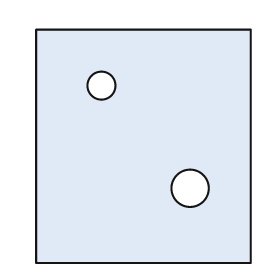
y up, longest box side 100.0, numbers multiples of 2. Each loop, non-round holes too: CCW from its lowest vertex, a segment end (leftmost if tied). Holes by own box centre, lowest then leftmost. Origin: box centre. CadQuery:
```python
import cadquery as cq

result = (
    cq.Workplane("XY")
    .moveTo(-46.0, -50.0)
    .lineTo(46.0, -50.0)
    .lineTo(46.0, 50.0)
    .lineTo(-46.0, 50.0)
    .close()
    .moveTo(20.0, -18.0)
    .circle(8.0)
    .moveTo(-18.0, 26.0)
    .circle(6.0)
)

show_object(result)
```